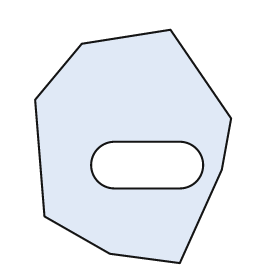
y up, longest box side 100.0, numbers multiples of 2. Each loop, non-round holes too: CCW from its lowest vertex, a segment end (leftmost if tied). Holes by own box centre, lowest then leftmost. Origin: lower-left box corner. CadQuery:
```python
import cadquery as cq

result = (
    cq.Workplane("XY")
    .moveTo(62.0, 0.0)
    .lineTo(80.0, 40.0)
    .lineTo(84.0, 62.0)
    .lineTo(58.0, 100.0)
    .lineTo(20.0, 94.0)
    .lineTo(0.0, 70.0)
    .lineTo(4.0, 20.0)
    .lineTo(32.0, 4.0)
    .close()
    .moveTo(34.0, 32.0)
    .lineTo(62.0, 32.0)
    .threePointArc((72.0, 42.0), (62.0, 52.0))
    .lineTo(34.0, 52.0)
    .threePointArc((24.0, 42.0), (34.0, 32.0))
    .close()
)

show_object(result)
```